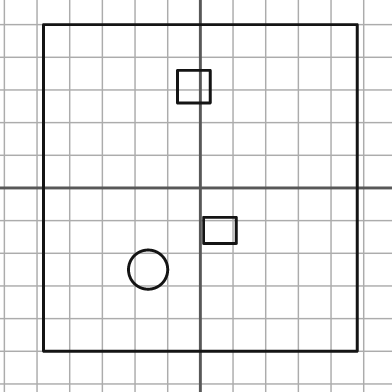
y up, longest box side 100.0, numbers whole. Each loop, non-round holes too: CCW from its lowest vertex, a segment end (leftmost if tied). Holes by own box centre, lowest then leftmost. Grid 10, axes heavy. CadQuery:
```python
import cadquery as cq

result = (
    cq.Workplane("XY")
    .moveTo(-48.0, -50.0)
    .lineTo(48.0, -50.0)
    .lineTo(48.0, 50.0)
    .lineTo(-48.0, 50.0)
    .close()
    .moveTo(-16.0, -25.0)
    .circle(6.0)
    .moveTo(1.0, -17.0)
    .lineTo(11.0, -17.0)
    .lineTo(11.0, -9.0)
    .lineTo(1.0, -9.0)
    .close()
    .moveTo(-7.0, 26.0)
    .lineTo(3.0, 26.0)
    .lineTo(3.0, 36.0)
    .lineTo(-7.0, 36.0)
    .close()
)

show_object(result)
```